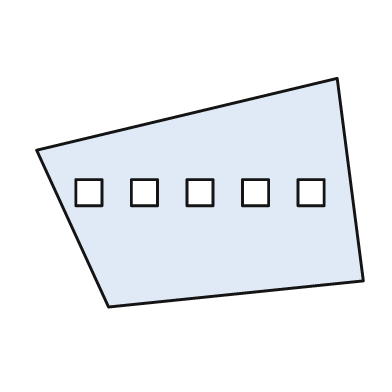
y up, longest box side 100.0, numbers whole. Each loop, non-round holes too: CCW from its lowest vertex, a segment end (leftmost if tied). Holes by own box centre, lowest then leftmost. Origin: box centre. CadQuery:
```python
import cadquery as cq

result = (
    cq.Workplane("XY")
    .moveTo(-28.0, -35.0)
    .lineTo(50.0, -27.0)
    .lineTo(42.0, 35.0)
    .lineTo(-50.0, 13.0)
    .close()
    .moveTo(-38.0, -4.0)
    .lineTo(-30.0, -4.0)
    .lineTo(-30.0, 4.0)
    .lineTo(-38.0, 4.0)
    .close()
    .moveTo(-21.0, -4.0)
    .lineTo(-13.0, -4.0)
    .lineTo(-13.0, 4.0)
    .lineTo(-21.0, 4.0)
    .close()
    .moveTo(-4.0, -4.0)
    .lineTo(4.0, -4.0)
    .lineTo(4.0, 4.0)
    .lineTo(-4.0, 4.0)
    .close()
    .moveTo(13.0, -4.0)
    .lineTo(21.0, -4.0)
    .lineTo(21.0, 4.0)
    .lineTo(13.0, 4.0)
    .close()
    .moveTo(30.0, -4.0)
    .lineTo(38.0, -4.0)
    .lineTo(38.0, 4.0)
    .lineTo(30.0, 4.0)
    .close()
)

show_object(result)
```